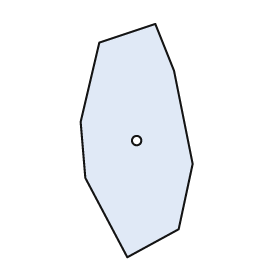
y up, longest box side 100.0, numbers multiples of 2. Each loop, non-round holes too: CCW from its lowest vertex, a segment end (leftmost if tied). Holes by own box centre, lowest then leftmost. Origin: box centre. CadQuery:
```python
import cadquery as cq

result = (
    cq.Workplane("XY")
    .moveTo(-4.0, -50.0)
    .lineTo(18.0, -38.0)
    .lineTo(24.0, -10.0)
    .lineTo(16.0, 30.0)
    .lineTo(8.0, 50.0)
    .lineTo(-16.0, 42.0)
    .lineTo(-24.0, 8.0)
    .lineTo(-22.0, -16.0)
    .close()
    .moveTo(0.0, 0.0)
    .circle(2.0)
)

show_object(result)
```